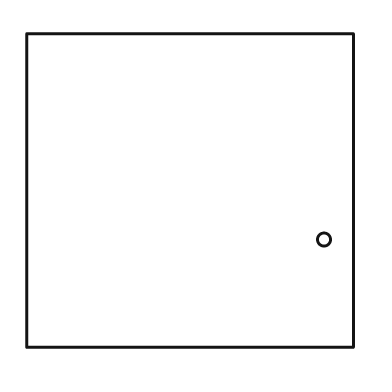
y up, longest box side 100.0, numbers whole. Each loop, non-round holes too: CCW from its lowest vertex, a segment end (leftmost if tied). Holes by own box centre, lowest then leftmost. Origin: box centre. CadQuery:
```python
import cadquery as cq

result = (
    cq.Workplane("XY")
    .moveTo(-50.0, -48.0)
    .lineTo(50.0, -48.0)
    .lineTo(50.0, 48.0)
    .lineTo(-50.0, 48.0)
    .close()
    .moveTo(41.0, -15.0)
    .circle(2.0)
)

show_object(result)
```